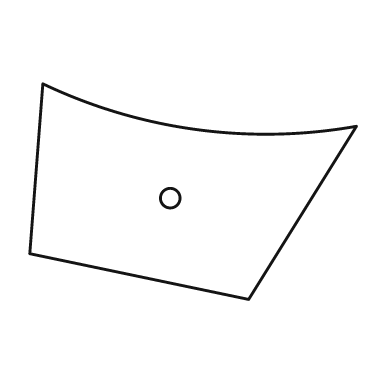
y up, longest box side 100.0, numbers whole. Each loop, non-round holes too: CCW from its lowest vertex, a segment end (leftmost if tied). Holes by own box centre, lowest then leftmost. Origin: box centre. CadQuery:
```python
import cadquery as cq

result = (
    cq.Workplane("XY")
    .moveTo(17.0, -33.0)
    .lineTo(50.0, 20.0)
    .threePointArc((1.0, 19.0), (-46.0, 33.0))
    .lineTo(-50.0, -19.0)
    .close()
    .moveTo(-7.0, -2.0)
    .circle(3.0)
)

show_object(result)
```